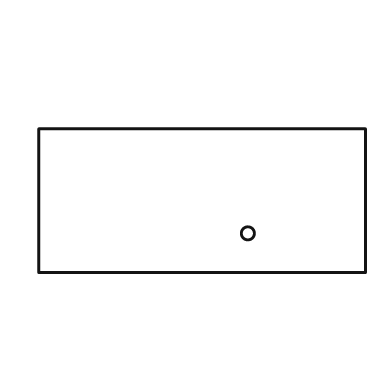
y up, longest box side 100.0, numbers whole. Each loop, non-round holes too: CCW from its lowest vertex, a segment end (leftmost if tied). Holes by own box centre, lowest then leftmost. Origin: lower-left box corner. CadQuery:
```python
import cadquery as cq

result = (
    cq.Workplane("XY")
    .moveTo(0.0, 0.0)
    .lineTo(100.0, 0.0)
    .lineTo(100.0, 44.0)
    .lineTo(0.0, 44.0)
    .close()
    .moveTo(64.0, 12.0)
    .circle(2.0)
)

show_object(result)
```